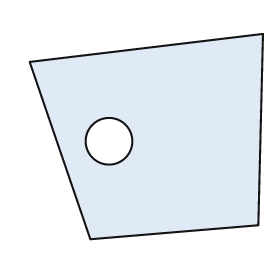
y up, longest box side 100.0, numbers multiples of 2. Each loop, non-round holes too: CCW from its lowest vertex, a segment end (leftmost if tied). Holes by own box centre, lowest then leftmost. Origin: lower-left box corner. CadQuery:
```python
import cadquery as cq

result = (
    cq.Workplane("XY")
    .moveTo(26.0, 0.0)
    .lineTo(98.0, 6.0)
    .lineTo(100.0, 88.0)
    .lineTo(0.0, 76.0)
    .close()
    .moveTo(34.0, 42.0)
    .circle(10.0)
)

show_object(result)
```